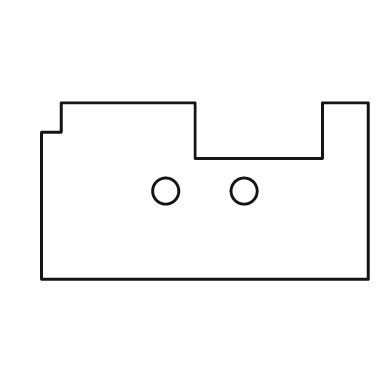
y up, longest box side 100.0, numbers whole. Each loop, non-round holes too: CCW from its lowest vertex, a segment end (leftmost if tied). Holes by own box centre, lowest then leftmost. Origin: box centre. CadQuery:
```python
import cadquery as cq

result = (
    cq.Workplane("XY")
    .moveTo(-50.0, -27.0)
    .lineTo(50.0, -27.0)
    .lineTo(50.0, 27.0)
    .lineTo(36.0, 27.0)
    .lineTo(36.0, 10.0)
    .lineTo(-3.0, 10.0)
    .lineTo(-3.0, 27.0)
    .lineTo(-44.0, 27.0)
    .lineTo(-44.0, 18.0)
    .lineTo(-50.0, 18.0)
    .close()
    .moveTo(-12.0, 0.0)
    .circle(4.0)
    .moveTo(12.0, 0.0)
    .circle(4.0)
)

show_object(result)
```